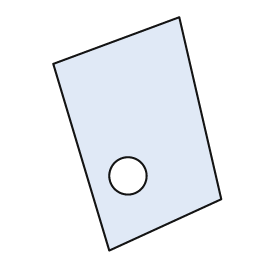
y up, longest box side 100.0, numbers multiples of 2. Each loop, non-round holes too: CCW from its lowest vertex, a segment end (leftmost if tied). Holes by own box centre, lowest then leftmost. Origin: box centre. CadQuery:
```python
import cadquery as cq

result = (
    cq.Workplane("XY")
    .moveTo(-12.0, -50.0)
    .lineTo(36.0, -28.0)
    .lineTo(18.0, 50.0)
    .lineTo(-36.0, 30.0)
    .close()
    .moveTo(-4.0, -18.0)
    .circle(8.0)
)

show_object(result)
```